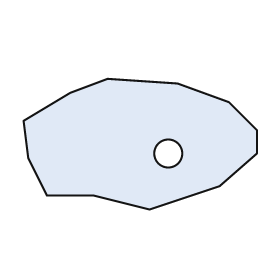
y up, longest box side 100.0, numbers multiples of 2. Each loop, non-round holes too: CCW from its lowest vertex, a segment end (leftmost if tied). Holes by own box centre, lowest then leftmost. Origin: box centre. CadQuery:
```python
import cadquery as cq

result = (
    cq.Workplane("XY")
    .moveTo(4.0, -28.0)
    .lineTo(34.0, -18.0)
    .lineTo(50.0, -4.0)
    .lineTo(50.0, 6.0)
    .lineTo(38.0, 18.0)
    .lineTo(16.0, 26.0)
    .lineTo(-14.0, 28.0)
    .lineTo(-30.0, 22.0)
    .lineTo(-50.0, 10.0)
    .lineTo(-48.0, -6.0)
    .lineTo(-40.0, -22.0)
    .lineTo(-20.0, -22.0)
    .close()
    .moveTo(12.0, -4.0)
    .circle(6.0)
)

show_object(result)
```